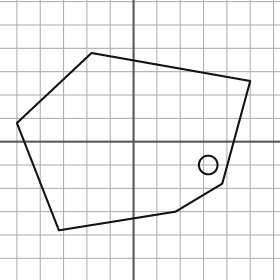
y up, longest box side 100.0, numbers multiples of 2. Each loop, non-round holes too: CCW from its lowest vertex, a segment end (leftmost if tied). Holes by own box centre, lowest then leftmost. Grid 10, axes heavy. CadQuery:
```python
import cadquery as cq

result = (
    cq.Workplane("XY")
    .moveTo(-32.0, -38.0)
    .lineTo(18.0, -30.0)
    .lineTo(38.0, -18.0)
    .lineTo(50.0, 26.0)
    .lineTo(-18.0, 38.0)
    .lineTo(-50.0, 8.0)
    .close()
    .moveTo(32.0, -10.0)
    .circle(4.0)
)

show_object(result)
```